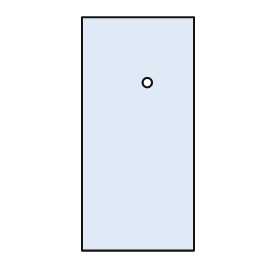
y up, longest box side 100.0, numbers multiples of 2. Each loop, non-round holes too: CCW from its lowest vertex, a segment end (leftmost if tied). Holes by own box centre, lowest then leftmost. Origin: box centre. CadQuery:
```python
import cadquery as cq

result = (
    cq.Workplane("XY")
    .moveTo(-24.0, -50.0)
    .lineTo(24.0, -50.0)
    .lineTo(24.0, 50.0)
    .lineTo(-24.0, 50.0)
    .close()
    .moveTo(4.0, 22.0)
    .circle(2.0)
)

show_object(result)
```